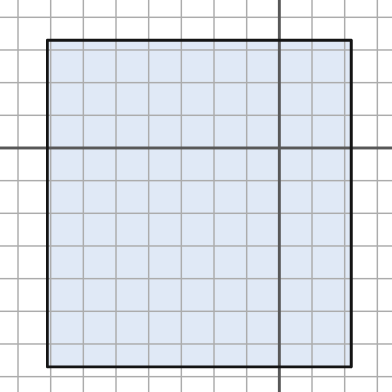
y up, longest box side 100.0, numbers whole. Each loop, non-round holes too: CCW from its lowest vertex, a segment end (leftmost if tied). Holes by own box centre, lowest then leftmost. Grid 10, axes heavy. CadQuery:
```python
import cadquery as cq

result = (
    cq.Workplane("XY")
    .moveTo(-71.0, -67.0)
    .lineTo(22.0, -67.0)
    .lineTo(22.0, 33.0)
    .lineTo(-71.0, 33.0)
    .close()
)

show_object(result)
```